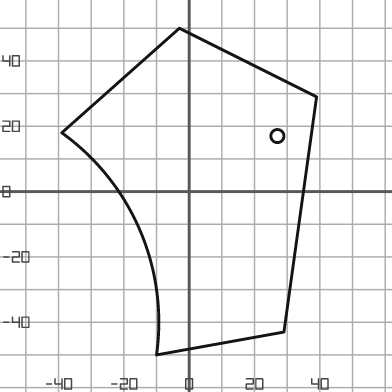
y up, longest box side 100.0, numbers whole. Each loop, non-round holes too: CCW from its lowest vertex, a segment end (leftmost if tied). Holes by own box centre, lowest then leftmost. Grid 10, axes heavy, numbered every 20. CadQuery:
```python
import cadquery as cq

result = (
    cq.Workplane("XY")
    .moveTo(-10.0, -50.0)
    .lineTo(29.0, -43.0)
    .lineTo(39.0, 29.0)
    .lineTo(-3.0, 50.0)
    .lineTo(-39.0, 18.0)
    .threePointArc((-15.0, -12.0), (-10.0, -50.0))
    .close()
    .moveTo(27.0, 17.0)
    .circle(2.0)
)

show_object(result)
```